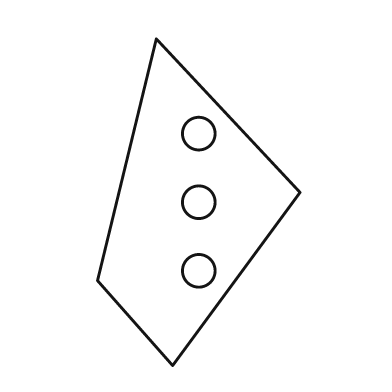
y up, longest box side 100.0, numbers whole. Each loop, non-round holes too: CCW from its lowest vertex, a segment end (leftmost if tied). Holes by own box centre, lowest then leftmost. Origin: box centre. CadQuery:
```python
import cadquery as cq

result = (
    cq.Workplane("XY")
    .moveTo(-8.0, -50.0)
    .lineTo(31.0, 3.0)
    .lineTo(-13.0, 50.0)
    .lineTo(-31.0, -24.0)
    .close()
    .moveTo(0.0, -21.0)
    .circle(5.0)
    .moveTo(0.0, 0.0)
    .circle(5.0)
    .moveTo(0.0, 21.0)
    .circle(5.0)
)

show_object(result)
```